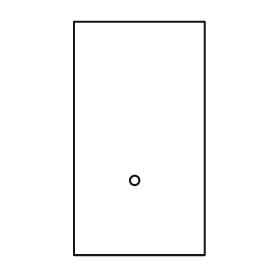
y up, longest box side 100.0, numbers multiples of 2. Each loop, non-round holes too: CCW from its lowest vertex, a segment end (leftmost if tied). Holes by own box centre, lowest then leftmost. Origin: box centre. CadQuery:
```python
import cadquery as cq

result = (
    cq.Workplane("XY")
    .moveTo(-28.0, -50.0)
    .lineTo(28.0, -50.0)
    .lineTo(28.0, 50.0)
    .lineTo(-28.0, 50.0)
    .close()
    .moveTo(-2.0, -18.0)
    .circle(2.0)
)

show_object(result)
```